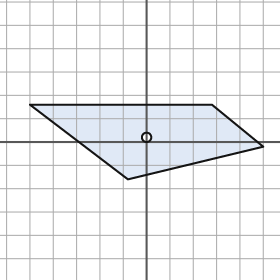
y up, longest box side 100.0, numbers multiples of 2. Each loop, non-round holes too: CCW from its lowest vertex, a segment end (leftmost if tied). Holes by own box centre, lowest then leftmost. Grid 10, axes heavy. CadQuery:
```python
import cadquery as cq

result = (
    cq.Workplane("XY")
    .moveTo(-8.0, -16.0)
    .lineTo(50.0, -2.0)
    .lineTo(28.0, 16.0)
    .lineTo(-50.0, 16.0)
    .close()
    .moveTo(0.0, 2.0)
    .circle(2.0)
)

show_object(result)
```